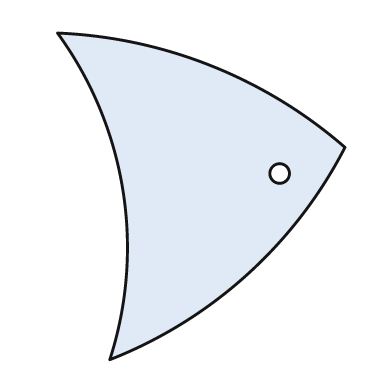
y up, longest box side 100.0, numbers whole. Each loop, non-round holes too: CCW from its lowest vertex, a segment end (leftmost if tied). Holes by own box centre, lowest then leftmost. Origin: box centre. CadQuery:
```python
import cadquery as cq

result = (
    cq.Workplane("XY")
    .moveTo(-28.0, -50.0)
    .threePointArc((14.0, -24.0), (44.0, 15.0))
    .threePointArc((3.0, 40.0), (-44.0, 50.0))
    .threePointArc((-24.0, 2.0), (-28.0, -50.0))
    .close()
    .moveTo(24.0, 7.0)
    .circle(3.0)
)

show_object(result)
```